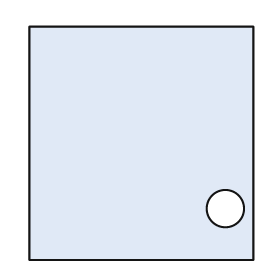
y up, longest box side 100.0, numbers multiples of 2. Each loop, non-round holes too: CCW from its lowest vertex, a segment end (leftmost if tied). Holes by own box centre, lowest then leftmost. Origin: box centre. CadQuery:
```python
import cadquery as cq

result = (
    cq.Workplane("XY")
    .moveTo(-48.0, -50.0)
    .lineTo(48.0, -50.0)
    .lineTo(48.0, 50.0)
    .lineTo(-48.0, 50.0)
    .close()
    .moveTo(36.0, -28.0)
    .circle(8.0)
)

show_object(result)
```